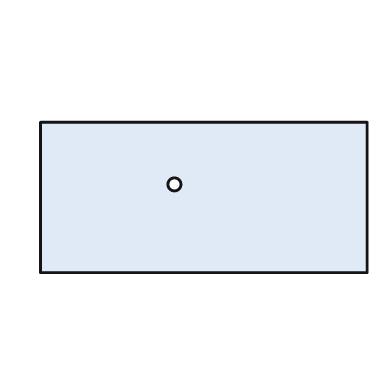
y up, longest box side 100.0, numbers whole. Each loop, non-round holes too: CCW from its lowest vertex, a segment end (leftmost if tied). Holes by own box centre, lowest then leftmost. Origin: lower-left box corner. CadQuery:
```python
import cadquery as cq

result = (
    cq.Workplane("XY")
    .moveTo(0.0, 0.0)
    .lineTo(100.0, 0.0)
    .lineTo(100.0, 46.0)
    .lineTo(0.0, 46.0)
    .close()
    .moveTo(41.0, 27.0)
    .circle(2.0)
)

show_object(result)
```